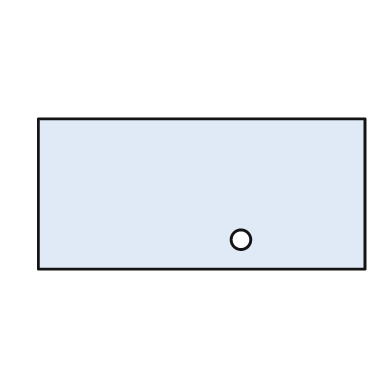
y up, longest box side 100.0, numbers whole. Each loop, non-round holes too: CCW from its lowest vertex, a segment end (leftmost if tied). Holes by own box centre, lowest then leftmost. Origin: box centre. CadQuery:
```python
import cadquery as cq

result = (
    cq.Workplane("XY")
    .moveTo(-50.0, -23.0)
    .lineTo(50.0, -23.0)
    .lineTo(50.0, 23.0)
    .lineTo(-50.0, 23.0)
    .close()
    .moveTo(12.0, -14.0)
    .circle(3.0)
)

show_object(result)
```